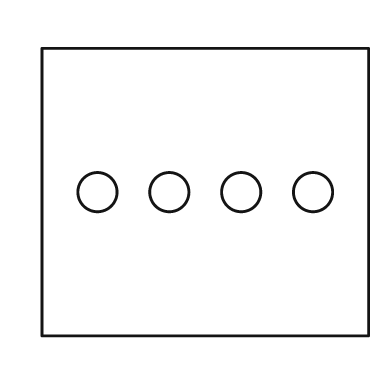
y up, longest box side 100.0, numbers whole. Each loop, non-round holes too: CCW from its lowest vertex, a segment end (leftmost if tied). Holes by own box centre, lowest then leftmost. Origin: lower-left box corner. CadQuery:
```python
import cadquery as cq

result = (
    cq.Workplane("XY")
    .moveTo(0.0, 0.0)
    .lineTo(100.0, 0.0)
    .lineTo(100.0, 88.0)
    .lineTo(0.0, 88.0)
    .close()
    .moveTo(17.0, 44.0)
    .circle(6.0)
    .moveTo(39.0, 44.0)
    .circle(6.0)
    .moveTo(61.0, 44.0)
    .circle(6.0)
    .moveTo(83.0, 44.0)
    .circle(6.0)
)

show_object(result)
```